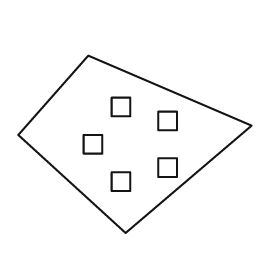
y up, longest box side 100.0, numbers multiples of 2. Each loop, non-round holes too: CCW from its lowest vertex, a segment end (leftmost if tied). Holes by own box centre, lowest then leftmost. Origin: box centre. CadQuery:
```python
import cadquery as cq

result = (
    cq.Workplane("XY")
    .moveTo(-4.0, -38.0)
    .lineTo(50.0, 8.0)
    .lineTo(-20.0, 38.0)
    .lineTo(-50.0, 4.0)
    .close()
    .moveTo(-10.0, -20.0)
    .lineTo(-2.0, -20.0)
    .lineTo(-2.0, -12.0)
    .lineTo(-10.0, -12.0)
    .close()
    .moveTo(10.0, -14.0)
    .lineTo(18.0, -14.0)
    .lineTo(18.0, -6.0)
    .lineTo(10.0, -6.0)
    .close()
    .moveTo(-22.0, -4.0)
    .lineTo(-14.0, -4.0)
    .lineTo(-14.0, 4.0)
    .lineTo(-22.0, 4.0)
    .close()
    .moveTo(10.0, 6.0)
    .lineTo(18.0, 6.0)
    .lineTo(18.0, 14.0)
    .lineTo(10.0, 14.0)
    .close()
    .moveTo(-10.0, 12.0)
    .lineTo(-2.0, 12.0)
    .lineTo(-2.0, 20.0)
    .lineTo(-10.0, 20.0)
    .close()
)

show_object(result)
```